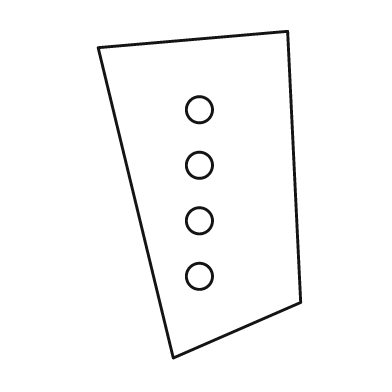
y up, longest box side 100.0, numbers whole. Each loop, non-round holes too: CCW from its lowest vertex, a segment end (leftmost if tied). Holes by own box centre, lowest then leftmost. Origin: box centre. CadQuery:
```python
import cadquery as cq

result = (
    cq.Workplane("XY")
    .moveTo(-8.0, -50.0)
    .lineTo(31.0, -33.0)
    .lineTo(27.0, 50.0)
    .lineTo(-31.0, 45.0)
    .close()
    .moveTo(0.0, -25.0)
    .circle(4.0)
    .moveTo(0.0, -8.0)
    .circle(4.0)
    .moveTo(0.0, 9.0)
    .circle(4.0)
    .moveTo(0.0, 26.0)
    .circle(4.0)
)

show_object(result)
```